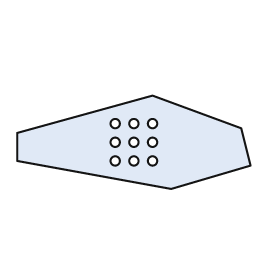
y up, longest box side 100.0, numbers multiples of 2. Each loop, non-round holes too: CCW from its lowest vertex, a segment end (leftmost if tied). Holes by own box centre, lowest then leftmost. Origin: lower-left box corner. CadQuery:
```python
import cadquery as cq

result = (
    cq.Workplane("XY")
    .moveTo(66.0, 0.0)
    .lineTo(100.0, 10.0)
    .lineTo(96.0, 26.0)
    .lineTo(58.0, 40.0)
    .lineTo(0.0, 24.0)
    .lineTo(0.0, 12.0)
    .close()
    .moveTo(42.0, 12.0)
    .circle(2.0)
    .moveTo(50.0, 12.0)
    .circle(2.0)
    .moveTo(58.0, 12.0)
    .circle(2.0)
    .moveTo(42.0, 20.0)
    .circle(2.0)
    .moveTo(50.0, 20.0)
    .circle(2.0)
    .moveTo(58.0, 20.0)
    .circle(2.0)
    .moveTo(42.0, 28.0)
    .circle(2.0)
    .moveTo(50.0, 28.0)
    .circle(2.0)
    .moveTo(58.0, 28.0)
    .circle(2.0)
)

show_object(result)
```